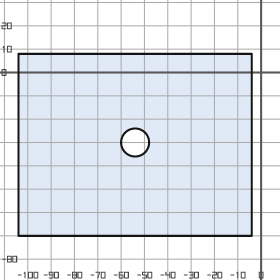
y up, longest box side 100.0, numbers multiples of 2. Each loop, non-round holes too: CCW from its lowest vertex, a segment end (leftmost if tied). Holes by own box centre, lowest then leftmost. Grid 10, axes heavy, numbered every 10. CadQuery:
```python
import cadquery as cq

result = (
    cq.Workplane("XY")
    .moveTo(-104.0, -70.0)
    .lineTo(-4.0, -70.0)
    .lineTo(-4.0, 8.0)
    .lineTo(-104.0, 8.0)
    .close()
    .moveTo(-54.0, -30.0)
    .circle(6.0)
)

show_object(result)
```